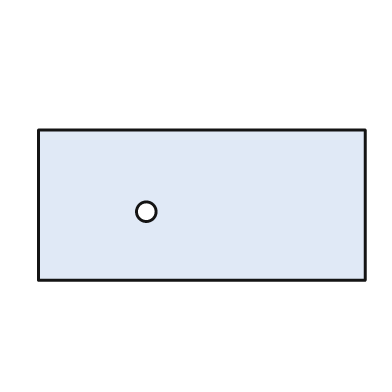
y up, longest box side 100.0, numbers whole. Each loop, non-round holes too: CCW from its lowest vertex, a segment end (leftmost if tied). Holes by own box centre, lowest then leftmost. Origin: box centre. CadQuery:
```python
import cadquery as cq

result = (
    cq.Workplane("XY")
    .moveTo(-50.0, -23.0)
    .lineTo(50.0, -23.0)
    .lineTo(50.0, 23.0)
    .lineTo(-50.0, 23.0)
    .close()
    .moveTo(-17.0, -2.0)
    .circle(3.0)
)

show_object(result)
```